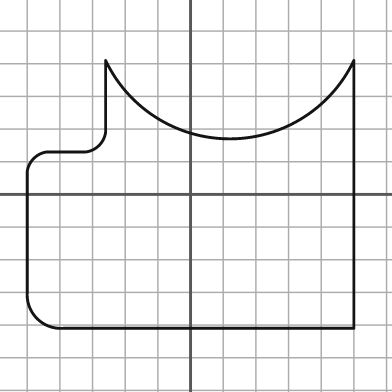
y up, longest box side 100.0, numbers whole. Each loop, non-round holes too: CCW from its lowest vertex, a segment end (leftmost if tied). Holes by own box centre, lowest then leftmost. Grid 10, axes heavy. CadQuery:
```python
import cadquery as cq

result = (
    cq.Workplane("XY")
    .moveTo(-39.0, -41.0)
    .lineTo(50.0, -41.0)
    .lineTo(50.0, 41.0)
    .threePointArc((12.0, 17.0), (-26.0, 41.0))
    .lineTo(-26.0, 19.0)
    .threePointArc((-28.0, 15.0), (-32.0, 13.0))
    .lineTo(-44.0, 13.0)
    .threePointArc((-48.0, 11.0), (-50.0, 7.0))
    .lineTo(-50.0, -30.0)
    .threePointArc((-47.0, -38.0), (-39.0, -41.0))
    .close()
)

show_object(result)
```